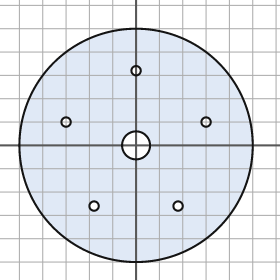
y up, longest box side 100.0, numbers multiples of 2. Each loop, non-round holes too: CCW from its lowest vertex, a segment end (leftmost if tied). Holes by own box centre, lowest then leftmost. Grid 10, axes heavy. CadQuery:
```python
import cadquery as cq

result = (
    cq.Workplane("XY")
    .moveTo(0.0, 0.0)
    .circle(50.0)
    .moveTo(-18.0, -26.0)
    .circle(2.0)
    .moveTo(18.0, -26.0)
    .circle(2.0)
    .moveTo(0.0, 0.0)
    .circle(6.0)
    .moveTo(-30.0, 10.0)
    .circle(2.0)
    .moveTo(30.0, 10.0)
    .circle(2.0)
    .moveTo(0.0, 32.0)
    .circle(2.0)
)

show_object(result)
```